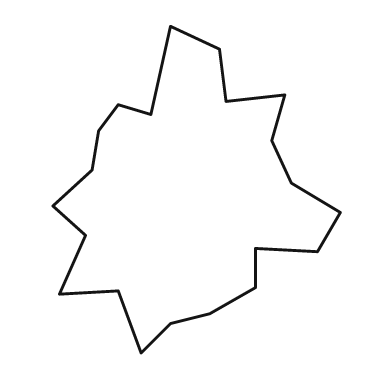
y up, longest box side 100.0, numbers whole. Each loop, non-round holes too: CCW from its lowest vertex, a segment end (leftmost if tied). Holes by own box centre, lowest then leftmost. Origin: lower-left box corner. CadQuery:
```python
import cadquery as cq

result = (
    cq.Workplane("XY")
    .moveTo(27.0, 0.0)
    .lineTo(36.0, 9.0)
    .lineTo(48.0, 12.0)
    .lineTo(62.0, 20.0)
    .lineTo(62.0, 32.0)
    .lineTo(81.0, 31.0)
    .lineTo(88.0, 43.0)
    .lineTo(73.0, 52.0)
    .lineTo(67.0, 65.0)
    .lineTo(71.0, 79.0)
    .lineTo(53.0, 77.0)
    .lineTo(51.0, 93.0)
    .lineTo(36.0, 100.0)
    .lineTo(30.0, 73.0)
    .lineTo(20.0, 76.0)
    .lineTo(14.0, 68.0)
    .lineTo(12.0, 56.0)
    .lineTo(0.0, 45.0)
    .lineTo(10.0, 36.0)
    .lineTo(2.0, 18.0)
    .lineTo(20.0, 19.0)
    .close()
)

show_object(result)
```